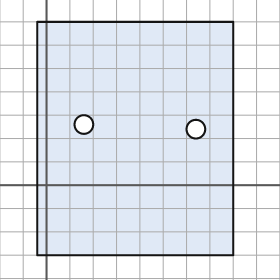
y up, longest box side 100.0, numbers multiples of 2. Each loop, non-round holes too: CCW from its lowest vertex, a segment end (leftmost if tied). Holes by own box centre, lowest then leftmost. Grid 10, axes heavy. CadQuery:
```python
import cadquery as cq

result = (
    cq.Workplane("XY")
    .moveTo(-4.0, -30.0)
    .lineTo(80.0, -30.0)
    .lineTo(80.0, 70.0)
    .lineTo(-4.0, 70.0)
    .close()
    .moveTo(64.0, 24.0)
    .circle(4.0)
    .moveTo(16.0, 26.0)
    .circle(4.0)
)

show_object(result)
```